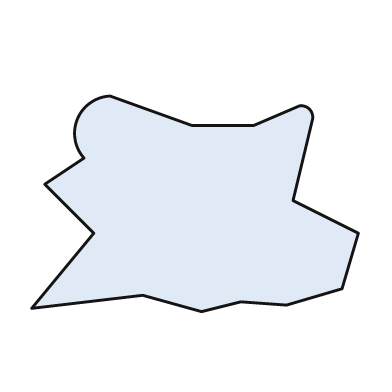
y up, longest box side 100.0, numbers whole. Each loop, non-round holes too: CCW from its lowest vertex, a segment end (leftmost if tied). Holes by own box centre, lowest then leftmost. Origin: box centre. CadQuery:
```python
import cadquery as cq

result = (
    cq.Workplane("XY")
    .moveTo(2.0, -33.0)
    .lineTo(14.0, -30.0)
    .lineTo(28.0, -31.0)
    .lineTo(45.0, -26.0)
    .lineTo(50.0, -9.0)
    .lineTo(30.0, 1.0)
    .lineTo(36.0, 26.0)
    .threePointArc((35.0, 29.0), (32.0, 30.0))
    .lineTo(18.0, 24.0)
    .lineTo(-1.0, 24.0)
    .lineTo(-26.0, 33.0)
    .threePointArc((-36.0, 26.0), (-34.0, 14.0))
    .lineTo(-46.0, 6.0)
    .lineTo(-31.0, -9.0)
    .lineTo(-50.0, -32.0)
    .lineTo(-16.0, -28.0)
    .close()
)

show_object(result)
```